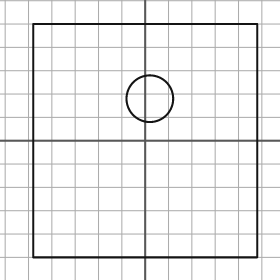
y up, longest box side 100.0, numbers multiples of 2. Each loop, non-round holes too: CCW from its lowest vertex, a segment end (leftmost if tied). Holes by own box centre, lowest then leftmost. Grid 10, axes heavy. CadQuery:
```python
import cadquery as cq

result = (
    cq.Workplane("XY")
    .moveTo(-48.0, -50.0)
    .lineTo(48.0, -50.0)
    .lineTo(48.0, 50.0)
    .lineTo(-48.0, 50.0)
    .close()
    .moveTo(2.0, 18.0)
    .circle(10.0)
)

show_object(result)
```